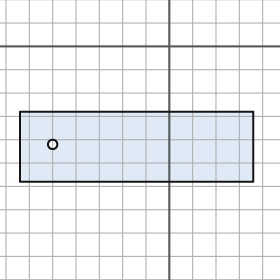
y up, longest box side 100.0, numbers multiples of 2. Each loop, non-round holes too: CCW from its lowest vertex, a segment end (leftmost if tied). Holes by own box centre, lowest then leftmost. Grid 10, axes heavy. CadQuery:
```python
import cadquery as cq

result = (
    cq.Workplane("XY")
    .moveTo(-64.0, -58.0)
    .lineTo(36.0, -58.0)
    .lineTo(36.0, -28.0)
    .lineTo(-64.0, -28.0)
    .close()
    .moveTo(-50.0, -42.0)
    .circle(2.0)
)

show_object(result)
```